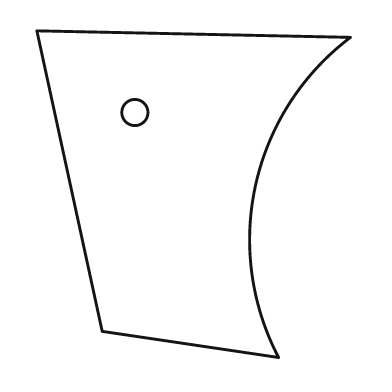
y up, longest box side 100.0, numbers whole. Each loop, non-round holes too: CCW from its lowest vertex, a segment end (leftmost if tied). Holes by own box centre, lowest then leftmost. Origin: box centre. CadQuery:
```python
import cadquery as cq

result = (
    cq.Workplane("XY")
    .moveTo(26.0, -50.0)
    .threePointArc((19.0, 3.0), (48.0, 48.0))
    .lineTo(-48.0, 50.0)
    .lineTo(-28.0, -42.0)
    .close()
    .moveTo(-18.0, 25.0)
    .circle(4.0)
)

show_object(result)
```